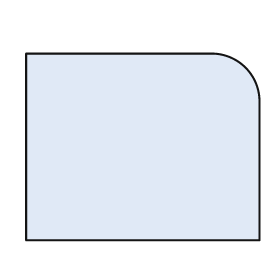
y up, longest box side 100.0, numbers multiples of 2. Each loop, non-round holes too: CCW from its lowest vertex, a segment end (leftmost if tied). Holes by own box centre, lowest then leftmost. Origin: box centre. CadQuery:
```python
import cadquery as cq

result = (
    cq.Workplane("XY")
    .moveTo(-50.0, -40.0)
    .lineTo(50.0, -40.0)
    .lineTo(50.0, 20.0)
    .threePointArc((44.0, 34.0), (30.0, 40.0))
    .lineTo(-50.0, 40.0)
    .close()
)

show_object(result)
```